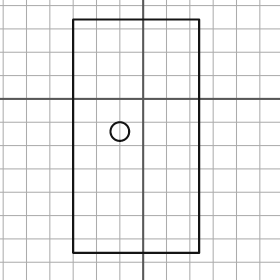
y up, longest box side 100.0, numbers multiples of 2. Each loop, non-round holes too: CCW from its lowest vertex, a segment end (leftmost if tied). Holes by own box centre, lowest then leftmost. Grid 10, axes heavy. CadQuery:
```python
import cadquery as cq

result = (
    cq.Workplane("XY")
    .moveTo(-30.0, -66.0)
    .lineTo(24.0, -66.0)
    .lineTo(24.0, 34.0)
    .lineTo(-30.0, 34.0)
    .close()
    .moveTo(-10.0, -14.0)
    .circle(4.0)
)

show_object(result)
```